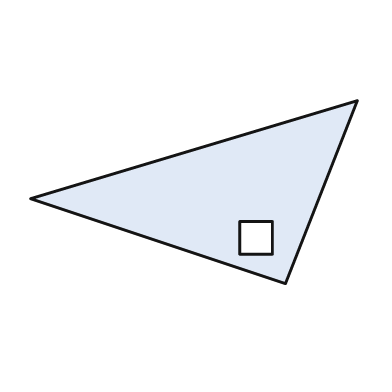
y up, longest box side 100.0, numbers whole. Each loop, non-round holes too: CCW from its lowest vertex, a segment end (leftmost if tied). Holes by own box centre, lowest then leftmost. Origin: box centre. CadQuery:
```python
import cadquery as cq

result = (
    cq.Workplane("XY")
    .moveTo(28.0, -28.0)
    .lineTo(50.0, 28.0)
    .lineTo(-50.0, -2.0)
    .close()
    .moveTo(14.0, -19.0)
    .lineTo(24.0, -19.0)
    .lineTo(24.0, -9.0)
    .lineTo(14.0, -9.0)
    .close()
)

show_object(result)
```